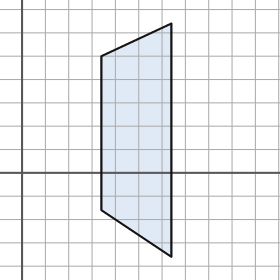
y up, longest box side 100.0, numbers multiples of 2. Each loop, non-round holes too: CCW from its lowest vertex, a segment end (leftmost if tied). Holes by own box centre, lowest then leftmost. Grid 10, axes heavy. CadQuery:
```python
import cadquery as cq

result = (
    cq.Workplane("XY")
    .moveTo(64.0, -36.0)
    .lineTo(64.0, 64.0)
    .lineTo(34.0, 50.0)
    .lineTo(34.0, -16.0)
    .close()
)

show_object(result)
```